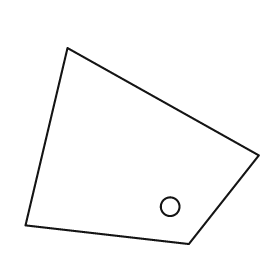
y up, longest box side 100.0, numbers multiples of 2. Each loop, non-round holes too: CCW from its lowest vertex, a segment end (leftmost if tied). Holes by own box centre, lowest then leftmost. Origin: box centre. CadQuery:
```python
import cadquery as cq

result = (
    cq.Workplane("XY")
    .moveTo(20.0, -42.0)
    .lineTo(50.0, -4.0)
    .lineTo(-32.0, 42.0)
    .lineTo(-50.0, -34.0)
    .close()
    .moveTo(12.0, -26.0)
    .circle(4.0)
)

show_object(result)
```